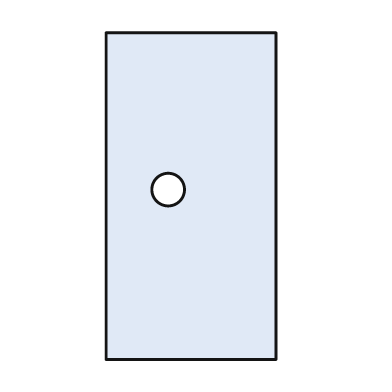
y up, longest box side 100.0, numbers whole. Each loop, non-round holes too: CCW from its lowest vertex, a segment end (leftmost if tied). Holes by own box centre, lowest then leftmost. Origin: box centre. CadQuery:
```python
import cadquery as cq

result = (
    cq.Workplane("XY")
    .moveTo(-26.0, -50.0)
    .lineTo(26.0, -50.0)
    .lineTo(26.0, 50.0)
    .lineTo(-26.0, 50.0)
    .close()
    .moveTo(-7.0, 2.0)
    .circle(5.0)
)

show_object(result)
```